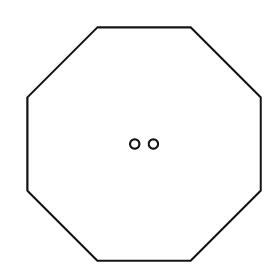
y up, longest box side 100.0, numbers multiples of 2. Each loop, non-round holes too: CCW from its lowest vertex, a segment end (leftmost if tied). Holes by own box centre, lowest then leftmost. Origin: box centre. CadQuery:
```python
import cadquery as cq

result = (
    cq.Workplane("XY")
    .moveTo(-20.0, -50.0)
    .lineTo(20.0, -50.0)
    .lineTo(50.0, -20.0)
    .lineTo(50.0, 20.0)
    .lineTo(20.0, 50.0)
    .lineTo(-20.0, 50.0)
    .lineTo(-50.0, 20.0)
    .lineTo(-50.0, -20.0)
    .close()
    .moveTo(-4.0, 0.0)
    .circle(2.0)
    .moveTo(4.0, 0.0)
    .circle(2.0)
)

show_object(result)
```